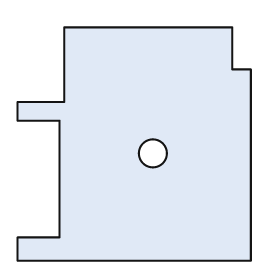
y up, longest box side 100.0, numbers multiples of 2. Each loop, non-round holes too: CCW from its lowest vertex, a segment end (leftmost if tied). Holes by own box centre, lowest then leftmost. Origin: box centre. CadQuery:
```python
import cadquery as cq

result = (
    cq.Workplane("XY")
    .moveTo(-50.0, -50.0)
    .lineTo(50.0, -50.0)
    .lineTo(50.0, 32.0)
    .lineTo(42.0, 32.0)
    .lineTo(42.0, 50.0)
    .lineTo(-30.0, 50.0)
    .lineTo(-30.0, 18.0)
    .lineTo(-50.0, 18.0)
    .lineTo(-50.0, 10.0)
    .lineTo(-32.0, 10.0)
    .lineTo(-32.0, -40.0)
    .lineTo(-50.0, -40.0)
    .close()
    .moveTo(8.0, -4.0)
    .circle(6.0)
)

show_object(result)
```